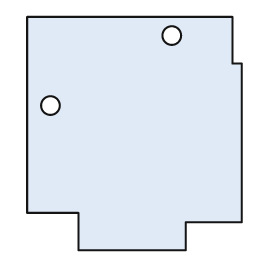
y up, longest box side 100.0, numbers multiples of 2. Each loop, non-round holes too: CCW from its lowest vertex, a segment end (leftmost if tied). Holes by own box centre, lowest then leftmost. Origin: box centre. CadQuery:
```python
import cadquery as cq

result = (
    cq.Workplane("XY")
    .moveTo(-24.0, -50.0)
    .lineTo(22.0, -50.0)
    .lineTo(22.0, -38.0)
    .lineTo(46.0, -38.0)
    .lineTo(46.0, 30.0)
    .lineTo(42.0, 30.0)
    .lineTo(42.0, 50.0)
    .lineTo(-46.0, 50.0)
    .lineTo(-46.0, -34.0)
    .lineTo(-24.0, -34.0)
    .close()
    .moveTo(-36.0, 12.0)
    .circle(4.0)
    .moveTo(16.0, 42.0)
    .circle(4.0)
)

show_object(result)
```